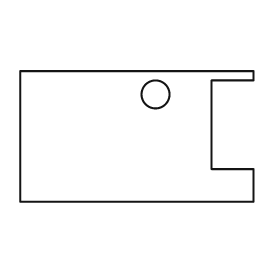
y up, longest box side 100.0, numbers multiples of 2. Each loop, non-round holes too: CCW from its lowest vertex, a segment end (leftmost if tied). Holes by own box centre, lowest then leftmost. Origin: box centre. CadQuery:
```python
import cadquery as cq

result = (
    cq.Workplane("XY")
    .moveTo(-50.0, -28.0)
    .lineTo(50.0, -28.0)
    .lineTo(50.0, -14.0)
    .lineTo(32.0, -14.0)
    .lineTo(32.0, 24.0)
    .lineTo(50.0, 24.0)
    .lineTo(50.0, 28.0)
    .lineTo(-50.0, 28.0)
    .close()
    .moveTo(8.0, 18.0)
    .circle(6.0)
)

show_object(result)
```